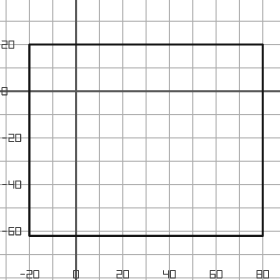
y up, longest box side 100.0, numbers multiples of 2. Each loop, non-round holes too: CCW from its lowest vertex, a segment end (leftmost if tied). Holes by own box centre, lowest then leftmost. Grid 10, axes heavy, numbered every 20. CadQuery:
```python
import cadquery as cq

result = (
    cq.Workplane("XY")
    .moveTo(-20.0, -62.0)
    .lineTo(80.0, -62.0)
    .lineTo(80.0, 20.0)
    .lineTo(-20.0, 20.0)
    .close()
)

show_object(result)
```